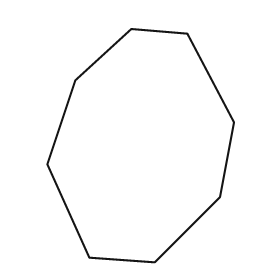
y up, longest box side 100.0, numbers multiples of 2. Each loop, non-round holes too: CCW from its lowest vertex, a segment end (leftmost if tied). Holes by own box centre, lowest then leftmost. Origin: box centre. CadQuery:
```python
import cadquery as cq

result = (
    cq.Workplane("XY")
    .moveTo(6.0, -50.0)
    .lineTo(34.0, -22.0)
    .lineTo(40.0, 10.0)
    .lineTo(20.0, 48.0)
    .lineTo(-4.0, 50.0)
    .lineTo(-28.0, 28.0)
    .lineTo(-40.0, -8.0)
    .lineTo(-22.0, -48.0)
    .close()
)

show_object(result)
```